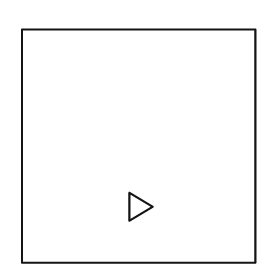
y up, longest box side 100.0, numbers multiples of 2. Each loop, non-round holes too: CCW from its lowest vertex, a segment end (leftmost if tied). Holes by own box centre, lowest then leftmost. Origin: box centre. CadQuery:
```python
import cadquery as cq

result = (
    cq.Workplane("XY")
    .moveTo(-50.0, -50.0)
    .lineTo(50.0, -50.0)
    .lineTo(50.0, 50.0)
    .lineTo(-50.0, 50.0)
    .close()
    .moveTo(-4.0, -32.0)
    .lineTo(6.0, -26.0)
    .lineTo(-4.0, -20.0)
    .close()
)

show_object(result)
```